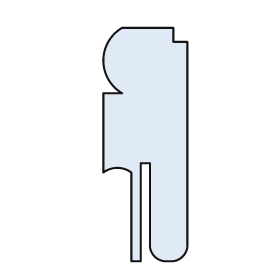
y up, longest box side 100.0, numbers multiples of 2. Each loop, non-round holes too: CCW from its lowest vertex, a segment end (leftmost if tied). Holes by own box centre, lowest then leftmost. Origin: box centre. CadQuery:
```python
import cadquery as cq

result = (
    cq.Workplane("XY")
    .moveTo(-6.0, -50.0)
    .lineTo(-2.0, -50.0)
    .lineTo(-2.0, -8.0)
    .lineTo(2.0, -8.0)
    .lineTo(2.0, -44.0)
    .threePointArc((4.0, -48.0), (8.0, -50.0))
    .lineTo(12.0, -50.0)
    .threePointArc((16.0, -48.0), (18.0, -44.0))
    .lineTo(18.0, 44.0)
    .lineTo(12.0, 44.0)
    .lineTo(12.0, 50.0)
    .lineTo(-10.0, 50.0)
    .threePointArc((-18.0, 36.0), (-10.0, 22.0))
    .lineTo(-18.0, 22.0)
    .lineTo(-18.0, -12.0)
    .threePointArc((-12.0, -10.0), (-6.0, -12.0))
    .close()
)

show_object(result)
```